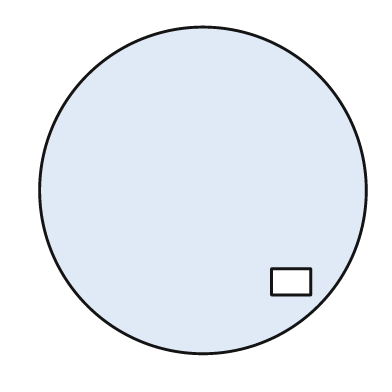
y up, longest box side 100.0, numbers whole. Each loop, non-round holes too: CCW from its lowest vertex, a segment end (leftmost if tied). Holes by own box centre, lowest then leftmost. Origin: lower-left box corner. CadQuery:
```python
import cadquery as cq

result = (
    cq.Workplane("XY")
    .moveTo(50.0, 50.0)
    .circle(50.0)
    .moveTo(71.0, 18.0)
    .lineTo(83.0, 18.0)
    .lineTo(83.0, 26.0)
    .lineTo(71.0, 26.0)
    .close()
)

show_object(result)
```